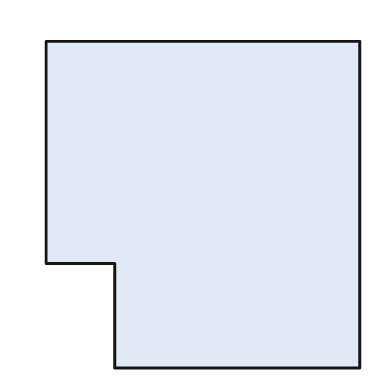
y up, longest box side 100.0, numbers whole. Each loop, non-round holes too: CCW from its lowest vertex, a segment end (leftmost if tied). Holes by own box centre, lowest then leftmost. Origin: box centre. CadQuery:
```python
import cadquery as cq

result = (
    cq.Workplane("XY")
    .moveTo(-27.0, -50.0)
    .lineTo(48.0, -50.0)
    .lineTo(48.0, 50.0)
    .lineTo(-48.0, 50.0)
    .lineTo(-48.0, -18.0)
    .lineTo(-27.0, -18.0)
    .close()
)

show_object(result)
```